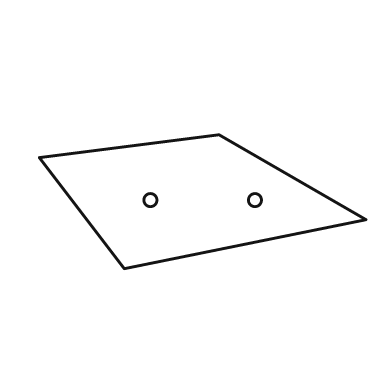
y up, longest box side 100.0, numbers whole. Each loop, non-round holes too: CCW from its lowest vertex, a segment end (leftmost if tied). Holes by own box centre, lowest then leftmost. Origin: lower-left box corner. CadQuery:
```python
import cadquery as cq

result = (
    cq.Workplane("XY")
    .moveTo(26.0, 0.0)
    .lineTo(100.0, 15.0)
    .lineTo(55.0, 41.0)
    .lineTo(0.0, 34.0)
    .close()
    .moveTo(34.0, 21.0)
    .circle(2.0)
    .moveTo(66.0, 21.0)
    .circle(2.0)
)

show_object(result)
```